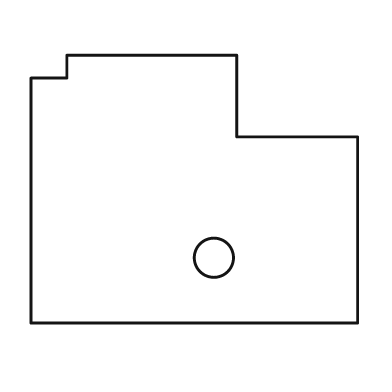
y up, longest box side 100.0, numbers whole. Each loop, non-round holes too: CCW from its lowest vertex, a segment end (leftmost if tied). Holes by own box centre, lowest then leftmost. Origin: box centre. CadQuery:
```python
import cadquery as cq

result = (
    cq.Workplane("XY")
    .moveTo(-50.0, -41.0)
    .lineTo(50.0, -41.0)
    .lineTo(50.0, 16.0)
    .lineTo(13.0, 16.0)
    .lineTo(13.0, 41.0)
    .lineTo(-39.0, 41.0)
    .lineTo(-39.0, 34.0)
    .lineTo(-50.0, 34.0)
    .close()
    .moveTo(6.0, -21.0)
    .circle(6.0)
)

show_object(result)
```